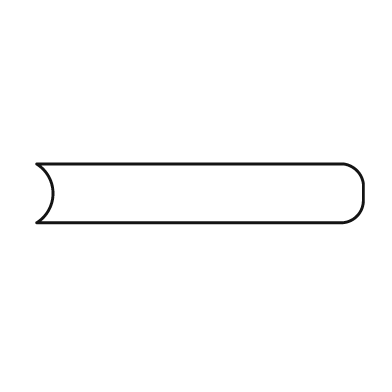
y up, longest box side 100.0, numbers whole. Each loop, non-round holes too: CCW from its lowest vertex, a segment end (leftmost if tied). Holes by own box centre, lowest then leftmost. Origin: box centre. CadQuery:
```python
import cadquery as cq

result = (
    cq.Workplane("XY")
    .moveTo(-50.0, -9.0)
    .lineTo(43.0, -9.0)
    .threePointArc((48.0, -7.0), (50.0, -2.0))
    .lineTo(50.0, 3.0)
    .threePointArc((48.0, 7.0), (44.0, 9.0))
    .lineTo(-50.0, 9.0)
    .threePointArc((-45.0, 0.0), (-50.0, -9.0))
    .close()
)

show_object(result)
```